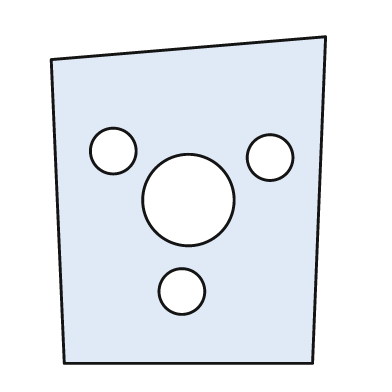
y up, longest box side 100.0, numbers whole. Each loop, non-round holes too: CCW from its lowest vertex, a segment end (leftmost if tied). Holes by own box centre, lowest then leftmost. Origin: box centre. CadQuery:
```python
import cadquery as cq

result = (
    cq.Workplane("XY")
    .moveTo(-38.0, -50.0)
    .lineTo(38.0, -50.0)
    .lineTo(42.0, 50.0)
    .lineTo(-42.0, 43.0)
    .close()
    .moveTo(-2.0, -28.0)
    .circle(7.0)
    .moveTo(0.0, 0.0)
    .circle(14.0)
    .moveTo(25.0, 13.0)
    .circle(7.0)
    .moveTo(-23.0, 15.0)
    .circle(7.0)
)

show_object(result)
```